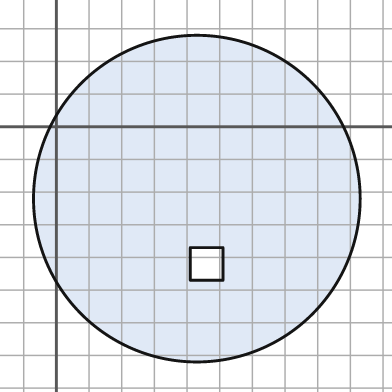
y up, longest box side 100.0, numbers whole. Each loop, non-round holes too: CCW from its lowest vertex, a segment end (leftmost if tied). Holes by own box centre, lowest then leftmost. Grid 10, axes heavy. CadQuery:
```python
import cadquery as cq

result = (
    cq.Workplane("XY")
    .moveTo(43.0, -22.0)
    .circle(50.0)
    .moveTo(41.0, -47.0)
    .lineTo(51.0, -47.0)
    .lineTo(51.0, -37.0)
    .lineTo(41.0, -37.0)
    .close()
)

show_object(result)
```